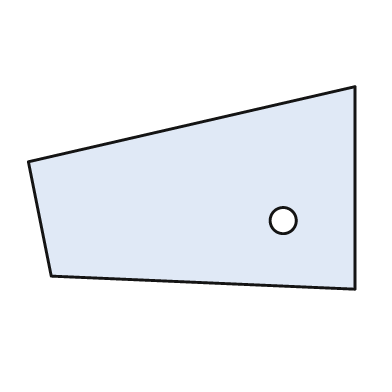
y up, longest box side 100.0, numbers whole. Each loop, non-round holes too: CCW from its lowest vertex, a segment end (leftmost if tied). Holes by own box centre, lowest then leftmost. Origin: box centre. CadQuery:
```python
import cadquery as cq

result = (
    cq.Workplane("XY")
    .moveTo(50.0, -31.0)
    .lineTo(50.0, 31.0)
    .lineTo(-50.0, 8.0)
    .lineTo(-43.0, -27.0)
    .close()
    .moveTo(28.0, -10.0)
    .circle(4.0)
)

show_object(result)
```